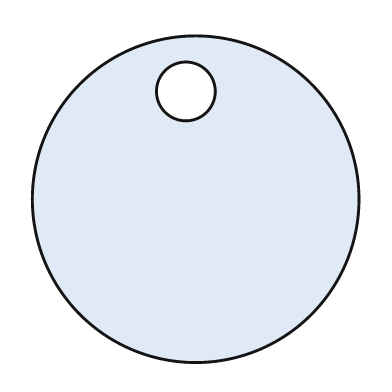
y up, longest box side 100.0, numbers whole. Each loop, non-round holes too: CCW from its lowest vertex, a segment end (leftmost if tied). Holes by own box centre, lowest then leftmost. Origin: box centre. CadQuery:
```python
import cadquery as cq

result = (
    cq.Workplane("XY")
    .moveTo(0.0, 0.0)
    .circle(50.0)
    .moveTo(-3.0, 33.0)
    .circle(9.0)
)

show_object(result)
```